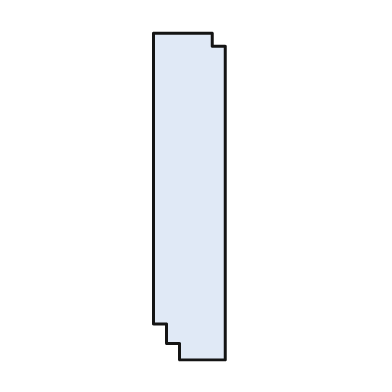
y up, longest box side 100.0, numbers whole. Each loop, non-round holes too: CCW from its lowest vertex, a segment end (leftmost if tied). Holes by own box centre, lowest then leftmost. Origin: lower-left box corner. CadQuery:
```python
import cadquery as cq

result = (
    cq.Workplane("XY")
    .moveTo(8.0, 0.0)
    .lineTo(22.0, 0.0)
    .lineTo(22.0, 96.0)
    .lineTo(18.0, 96.0)
    .lineTo(18.0, 100.0)
    .lineTo(0.0, 100.0)
    .lineTo(0.0, 11.0)
    .lineTo(4.0, 11.0)
    .lineTo(4.0, 5.0)
    .lineTo(8.0, 5.0)
    .close()
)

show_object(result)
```